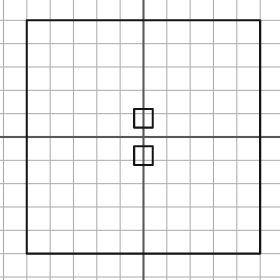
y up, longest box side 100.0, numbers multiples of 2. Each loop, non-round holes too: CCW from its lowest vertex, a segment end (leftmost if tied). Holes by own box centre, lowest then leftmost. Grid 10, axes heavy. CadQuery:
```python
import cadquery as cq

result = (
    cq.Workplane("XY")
    .moveTo(-50.0, -50.0)
    .lineTo(50.0, -50.0)
    .lineTo(50.0, 50.0)
    .lineTo(-50.0, 50.0)
    .close()
    .moveTo(-4.0, -12.0)
    .lineTo(4.0, -12.0)
    .lineTo(4.0, -4.0)
    .lineTo(-4.0, -4.0)
    .close()
    .moveTo(-4.0, 4.0)
    .lineTo(4.0, 4.0)
    .lineTo(4.0, 12.0)
    .lineTo(-4.0, 12.0)
    .close()
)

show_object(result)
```